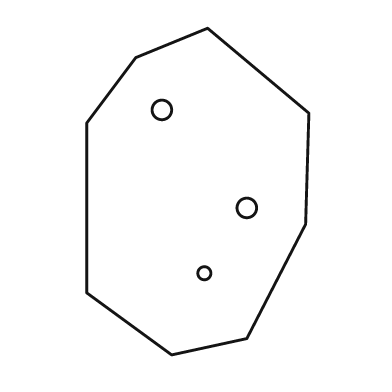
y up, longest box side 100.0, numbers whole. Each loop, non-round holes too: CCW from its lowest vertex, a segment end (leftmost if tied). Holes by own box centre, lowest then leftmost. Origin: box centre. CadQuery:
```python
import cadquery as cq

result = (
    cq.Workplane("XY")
    .moveTo(-8.0, -50.0)
    .lineTo(15.0, -45.0)
    .lineTo(33.0, -10.0)
    .lineTo(34.0, 24.0)
    .lineTo(3.0, 50.0)
    .lineTo(-19.0, 41.0)
    .lineTo(-34.0, 21.0)
    .lineTo(-34.0, -31.0)
    .close()
    .moveTo(2.0, -25.0)
    .circle(2.0)
    .moveTo(15.0, -5.0)
    .circle(3.0)
    .moveTo(-11.0, 25.0)
    .circle(3.0)
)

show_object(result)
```